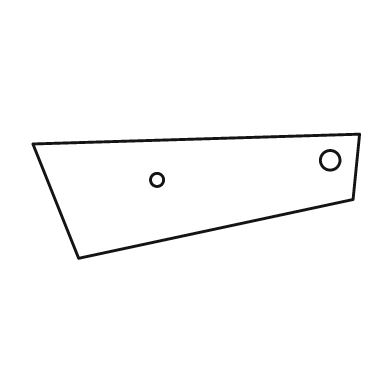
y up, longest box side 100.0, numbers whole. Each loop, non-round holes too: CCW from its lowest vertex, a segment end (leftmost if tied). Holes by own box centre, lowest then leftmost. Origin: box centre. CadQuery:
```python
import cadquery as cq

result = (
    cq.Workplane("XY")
    .moveTo(-36.0, -19.0)
    .lineTo(48.0, -1.0)
    .lineTo(50.0, 19.0)
    .lineTo(-50.0, 16.0)
    .close()
    .moveTo(-12.0, 5.0)
    .circle(2.0)
    .moveTo(41.0, 11.0)
    .circle(3.0)
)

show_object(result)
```